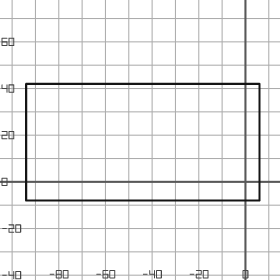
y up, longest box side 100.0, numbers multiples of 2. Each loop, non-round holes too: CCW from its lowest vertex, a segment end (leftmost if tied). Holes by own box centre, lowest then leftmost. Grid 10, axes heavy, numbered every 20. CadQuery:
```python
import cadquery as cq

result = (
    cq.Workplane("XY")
    .moveTo(-94.0, -8.0)
    .lineTo(6.0, -8.0)
    .lineTo(6.0, 42.0)
    .lineTo(-94.0, 42.0)
    .close()
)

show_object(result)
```